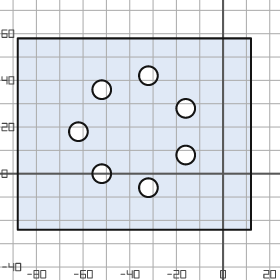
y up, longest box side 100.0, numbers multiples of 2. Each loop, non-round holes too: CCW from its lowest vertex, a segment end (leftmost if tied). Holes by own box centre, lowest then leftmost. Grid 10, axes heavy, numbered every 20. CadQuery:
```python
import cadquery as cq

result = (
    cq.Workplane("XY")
    .moveTo(-88.0, -24.0)
    .lineTo(12.0, -24.0)
    .lineTo(12.0, 58.0)
    .lineTo(-88.0, 58.0)
    .close()
    .moveTo(-32.0, -6.0)
    .circle(4.0)
    .moveTo(-52.0, 0.0)
    .circle(4.0)
    .moveTo(-16.0, 8.0)
    .circle(4.0)
    .moveTo(-62.0, 18.0)
    .circle(4.0)
    .moveTo(-16.0, 28.0)
    .circle(4.0)
    .moveTo(-52.0, 36.0)
    .circle(4.0)
    .moveTo(-32.0, 42.0)
    .circle(4.0)
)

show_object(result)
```